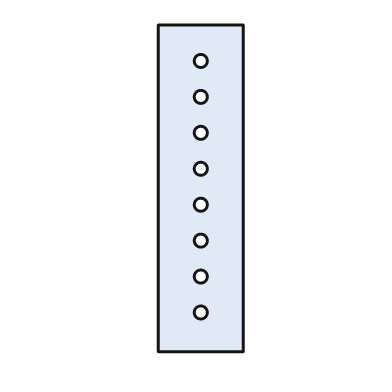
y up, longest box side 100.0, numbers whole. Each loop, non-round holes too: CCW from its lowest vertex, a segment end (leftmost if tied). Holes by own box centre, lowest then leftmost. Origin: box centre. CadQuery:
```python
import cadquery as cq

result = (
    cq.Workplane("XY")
    .moveTo(-13.0, -50.0)
    .lineTo(13.0, -50.0)
    .lineTo(13.0, 50.0)
    .lineTo(-13.0, 50.0)
    .close()
    .moveTo(0.0, -38.0)
    .circle(2.0)
    .moveTo(0.0, -27.0)
    .circle(2.0)
    .moveTo(0.0, -16.0)
    .circle(2.0)
    .moveTo(0.0, -5.0)
    .circle(2.0)
    .moveTo(0.0, 6.0)
    .circle(2.0)
    .moveTo(0.0, 17.0)
    .circle(2.0)
    .moveTo(0.0, 28.0)
    .circle(2.0)
    .moveTo(0.0, 39.0)
    .circle(2.0)
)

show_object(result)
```